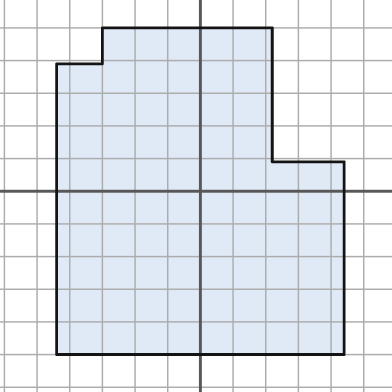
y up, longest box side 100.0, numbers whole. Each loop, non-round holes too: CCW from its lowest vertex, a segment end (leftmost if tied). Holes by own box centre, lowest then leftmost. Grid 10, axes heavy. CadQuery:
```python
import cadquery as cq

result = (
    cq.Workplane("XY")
    .moveTo(-44.0, -50.0)
    .lineTo(44.0, -50.0)
    .lineTo(44.0, 9.0)
    .lineTo(22.0, 9.0)
    .lineTo(22.0, 50.0)
    .lineTo(-30.0, 50.0)
    .lineTo(-30.0, 39.0)
    .lineTo(-44.0, 39.0)
    .close()
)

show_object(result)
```